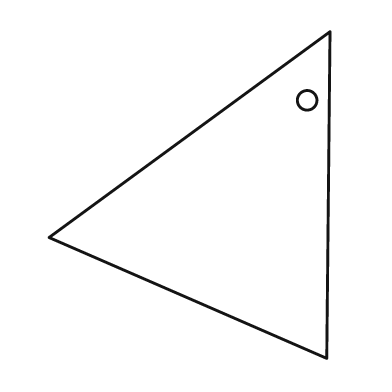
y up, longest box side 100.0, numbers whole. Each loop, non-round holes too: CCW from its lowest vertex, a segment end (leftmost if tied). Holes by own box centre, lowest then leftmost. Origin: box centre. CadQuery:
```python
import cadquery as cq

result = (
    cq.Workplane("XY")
    .moveTo(42.0, -50.0)
    .lineTo(43.0, 50.0)
    .lineTo(-43.0, -13.0)
    .close()
    .moveTo(36.0, 29.0)
    .circle(3.0)
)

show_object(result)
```